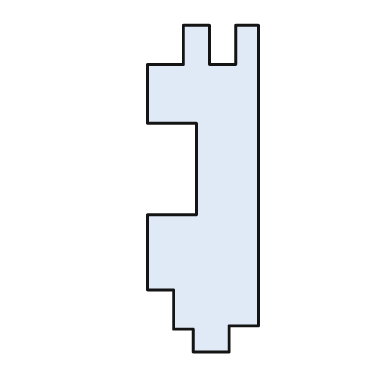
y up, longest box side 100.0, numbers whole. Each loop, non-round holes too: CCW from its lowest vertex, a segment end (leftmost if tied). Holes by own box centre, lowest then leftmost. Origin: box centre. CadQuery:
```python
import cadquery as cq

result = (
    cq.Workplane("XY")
    .moveTo(-3.0, -50.0)
    .lineTo(8.0, -50.0)
    .lineTo(8.0, -42.0)
    .lineTo(17.0, -42.0)
    .lineTo(17.0, 50.0)
    .lineTo(10.0, 50.0)
    .lineTo(10.0, 38.0)
    .lineTo(2.0, 38.0)
    .lineTo(2.0, 50.0)
    .lineTo(-6.0, 50.0)
    .lineTo(-6.0, 38.0)
    .lineTo(-17.0, 38.0)
    .lineTo(-17.0, 20.0)
    .lineTo(-2.0, 20.0)
    .lineTo(-2.0, -8.0)
    .lineTo(-17.0, -8.0)
    .lineTo(-17.0, -31.0)
    .lineTo(-9.0, -31.0)
    .lineTo(-9.0, -43.0)
    .lineTo(-3.0, -43.0)
    .close()
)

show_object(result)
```